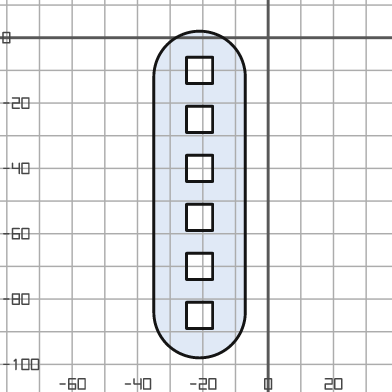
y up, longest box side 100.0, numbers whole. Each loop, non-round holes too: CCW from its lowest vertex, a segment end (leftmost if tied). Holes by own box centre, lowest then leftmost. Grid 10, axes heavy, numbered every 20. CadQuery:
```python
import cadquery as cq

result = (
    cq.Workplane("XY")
    .moveTo(-35.0, -84.0)
    .threePointArc((-21.0, -98.0), (-7.0, -84.0))
    .lineTo(-7.0, -12.0)
    .threePointArc((-21.0, 2.0), (-35.0, -12.0))
    .close()
    .moveTo(-25.0, -89.0)
    .lineTo(-17.0, -89.0)
    .lineTo(-17.0, -81.0)
    .lineTo(-25.0, -81.0)
    .close()
    .moveTo(-25.0, -74.0)
    .lineTo(-17.0, -74.0)
    .lineTo(-17.0, -66.0)
    .lineTo(-25.0, -66.0)
    .close()
    .moveTo(-25.0, -59.0)
    .lineTo(-17.0, -59.0)
    .lineTo(-17.0, -51.0)
    .lineTo(-25.0, -51.0)
    .close()
    .moveTo(-25.0, -44.0)
    .lineTo(-17.0, -44.0)
    .lineTo(-17.0, -36.0)
    .lineTo(-25.0, -36.0)
    .close()
    .moveTo(-25.0, -29.0)
    .lineTo(-17.0, -29.0)
    .lineTo(-17.0, -21.0)
    .lineTo(-25.0, -21.0)
    .close()
    .moveTo(-25.0, -14.0)
    .lineTo(-17.0, -14.0)
    .lineTo(-17.0, -6.0)
    .lineTo(-25.0, -6.0)
    .close()
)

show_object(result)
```